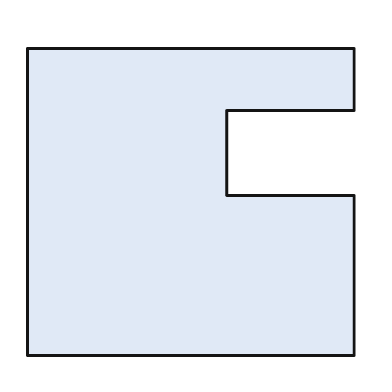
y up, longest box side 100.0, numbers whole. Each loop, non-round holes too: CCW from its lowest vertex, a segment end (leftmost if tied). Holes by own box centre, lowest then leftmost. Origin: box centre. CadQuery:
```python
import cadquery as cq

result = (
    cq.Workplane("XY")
    .moveTo(-50.0, -47.0)
    .lineTo(50.0, -47.0)
    .lineTo(50.0, 2.0)
    .lineTo(11.0, 2.0)
    .lineTo(11.0, 28.0)
    .lineTo(50.0, 28.0)
    .lineTo(50.0, 47.0)
    .lineTo(-50.0, 47.0)
    .close()
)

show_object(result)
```